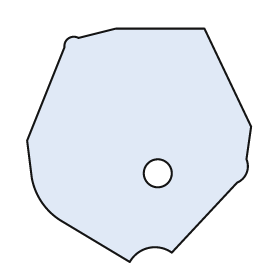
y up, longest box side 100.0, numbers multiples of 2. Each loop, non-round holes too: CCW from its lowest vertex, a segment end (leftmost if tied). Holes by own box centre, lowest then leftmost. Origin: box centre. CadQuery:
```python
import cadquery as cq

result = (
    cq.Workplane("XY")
    .moveTo(-4.0, -50.0)
    .threePointArc((4.0, -44.0), (14.0, -46.0))
    .lineTo(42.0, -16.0)
    .threePointArc((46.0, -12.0), (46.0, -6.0))
    .lineTo(48.0, 8.0)
    .lineTo(28.0, 50.0)
    .lineTo(-10.0, 50.0)
    .lineTo(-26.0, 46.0)
    .threePointArc((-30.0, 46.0), (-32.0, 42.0))
    .lineTo(-48.0, 2.0)
    .lineTo(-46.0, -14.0)
    .threePointArc((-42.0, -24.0), (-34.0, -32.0))
    .close()
    .moveTo(8.0, -12.0)
    .circle(6.0)
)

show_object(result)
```